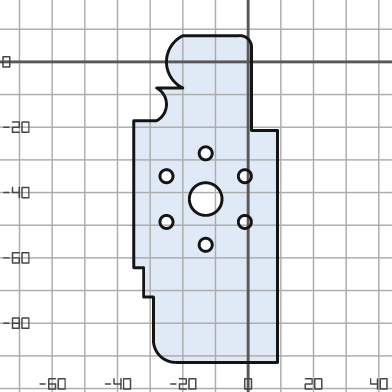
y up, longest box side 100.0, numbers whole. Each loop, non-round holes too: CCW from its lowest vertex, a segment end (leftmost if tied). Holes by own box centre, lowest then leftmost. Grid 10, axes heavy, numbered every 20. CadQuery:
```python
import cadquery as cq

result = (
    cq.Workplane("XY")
    .moveTo(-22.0, -92.0)
    .lineTo(9.0, -92.0)
    .lineTo(9.0, -21.0)
    .lineTo(1.0, -21.0)
    .lineTo(1.0, 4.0)
    .threePointArc((0.0, 7.0), (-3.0, 8.0))
    .lineTo(-20.0, 8.0)
    .threePointArc((-25.0, 0.0), (-20.0, -8.0))
    .lineTo(-28.0, -8.0)
    .threePointArc((-25.0, -13.0), (-28.0, -18.0))
    .lineTo(-35.0, -18.0)
    .lineTo(-35.0, -63.0)
    .lineTo(-32.0, -63.0)
    .lineTo(-32.0, -72.0)
    .lineTo(-29.0, -72.0)
    .lineTo(-29.0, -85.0)
    .threePointArc((-27.0, -90.0), (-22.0, -92.0))
    .close()
    .moveTo(-13.0, -56.0)
    .circle(2.0)
    .moveTo(-25.0, -49.0)
    .circle(2.0)
    .moveTo(-1.0, -49.0)
    .circle(2.0)
    .moveTo(-13.0, -42.0)
    .circle(5.0)
    .moveTo(-25.0, -35.0)
    .circle(2.0)
    .moveTo(-1.0, -35.0)
    .circle(2.0)
    .moveTo(-13.0, -28.0)
    .circle(2.0)
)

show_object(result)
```